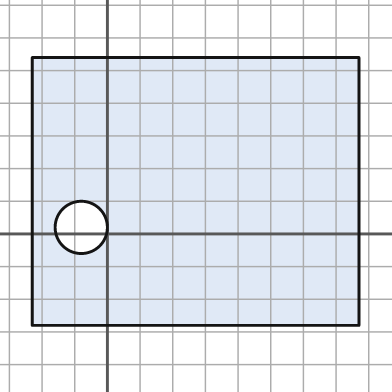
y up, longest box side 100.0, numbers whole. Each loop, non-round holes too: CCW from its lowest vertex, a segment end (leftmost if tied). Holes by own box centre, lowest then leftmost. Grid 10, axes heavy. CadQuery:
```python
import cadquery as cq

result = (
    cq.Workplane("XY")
    .moveTo(-23.0, -28.0)
    .lineTo(77.0, -28.0)
    .lineTo(77.0, 54.0)
    .lineTo(-23.0, 54.0)
    .close()
    .moveTo(-8.0, 2.0)
    .circle(8.0)
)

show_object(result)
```